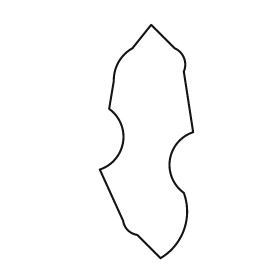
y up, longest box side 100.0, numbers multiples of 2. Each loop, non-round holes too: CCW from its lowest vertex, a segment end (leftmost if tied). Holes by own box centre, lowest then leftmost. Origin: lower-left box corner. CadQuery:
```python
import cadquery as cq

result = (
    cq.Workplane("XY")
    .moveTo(26.0, 0.0)
    .threePointArc((36.0, 12.0), (36.0, 28.0))
    .threePointArc((30.0, 42.0), (40.0, 54.0))
    .lineTo(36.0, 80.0)
    .threePointArc((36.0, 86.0), (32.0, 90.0))
    .lineTo(22.0, 100.0)
    .lineTo(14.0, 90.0)
    .threePointArc((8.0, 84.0), (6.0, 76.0))
    .lineTo(4.0, 64.0)
    .threePointArc((10.0, 50.0), (0.0, 38.0))
    .lineTo(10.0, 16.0)
    .threePointArc((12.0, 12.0), (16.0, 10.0))
    .close()
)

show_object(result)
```